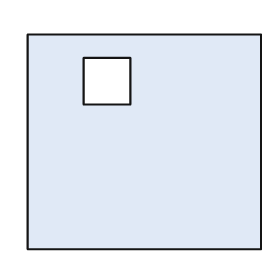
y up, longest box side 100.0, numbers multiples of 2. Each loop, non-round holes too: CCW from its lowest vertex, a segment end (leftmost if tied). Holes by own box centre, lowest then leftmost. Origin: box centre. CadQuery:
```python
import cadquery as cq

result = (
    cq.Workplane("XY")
    .moveTo(-50.0, -46.0)
    .lineTo(50.0, -46.0)
    .lineTo(50.0, 46.0)
    .lineTo(-50.0, 46.0)
    .close()
    .moveTo(-26.0, 16.0)
    .lineTo(-6.0, 16.0)
    .lineTo(-6.0, 36.0)
    .lineTo(-26.0, 36.0)
    .close()
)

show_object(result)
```